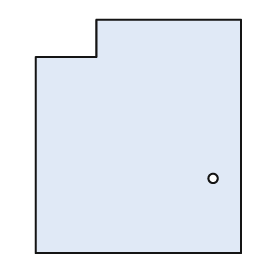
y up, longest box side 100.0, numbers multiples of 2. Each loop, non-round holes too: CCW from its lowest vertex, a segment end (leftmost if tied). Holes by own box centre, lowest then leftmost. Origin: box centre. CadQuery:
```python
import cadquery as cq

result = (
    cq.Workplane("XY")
    .moveTo(-44.0, -50.0)
    .lineTo(44.0, -50.0)
    .lineTo(44.0, 50.0)
    .lineTo(-18.0, 50.0)
    .lineTo(-18.0, 34.0)
    .lineTo(-44.0, 34.0)
    .close()
    .moveTo(32.0, -18.0)
    .circle(2.0)
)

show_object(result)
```